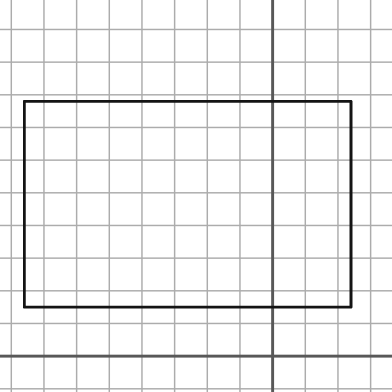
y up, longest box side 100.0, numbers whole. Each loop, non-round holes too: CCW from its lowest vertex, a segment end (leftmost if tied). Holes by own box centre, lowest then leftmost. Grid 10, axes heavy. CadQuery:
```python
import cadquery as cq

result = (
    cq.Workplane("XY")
    .moveTo(-76.0, 15.0)
    .lineTo(24.0, 15.0)
    .lineTo(24.0, 78.0)
    .lineTo(-76.0, 78.0)
    .close()
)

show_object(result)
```